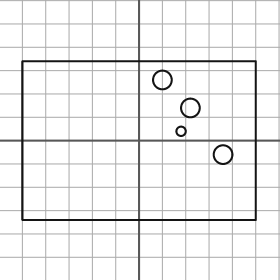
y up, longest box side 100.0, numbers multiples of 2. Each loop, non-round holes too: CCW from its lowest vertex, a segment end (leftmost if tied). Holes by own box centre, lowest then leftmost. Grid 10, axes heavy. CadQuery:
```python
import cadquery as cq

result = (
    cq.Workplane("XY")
    .moveTo(-50.0, -34.0)
    .lineTo(50.0, -34.0)
    .lineTo(50.0, 34.0)
    .lineTo(-50.0, 34.0)
    .close()
    .moveTo(36.0, -6.0)
    .circle(4.0)
    .moveTo(18.0, 4.0)
    .circle(2.0)
    .moveTo(22.0, 14.0)
    .circle(4.0)
    .moveTo(10.0, 26.0)
    .circle(4.0)
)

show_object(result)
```